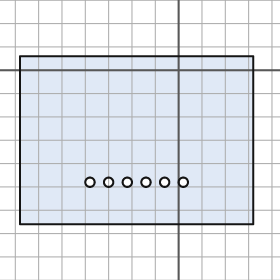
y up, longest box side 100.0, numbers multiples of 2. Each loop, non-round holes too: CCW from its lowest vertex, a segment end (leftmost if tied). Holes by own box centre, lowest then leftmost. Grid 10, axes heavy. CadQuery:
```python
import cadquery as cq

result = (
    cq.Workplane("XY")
    .moveTo(-68.0, -66.0)
    .lineTo(32.0, -66.0)
    .lineTo(32.0, 6.0)
    .lineTo(-68.0, 6.0)
    .close()
    .moveTo(-38.0, -48.0)
    .circle(2.0)
    .moveTo(-30.0, -48.0)
    .circle(2.0)
    .moveTo(-22.0, -48.0)
    .circle(2.0)
    .moveTo(-14.0, -48.0)
    .circle(2.0)
    .moveTo(-6.0, -48.0)
    .circle(2.0)
    .moveTo(2.0, -48.0)
    .circle(2.0)
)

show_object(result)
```